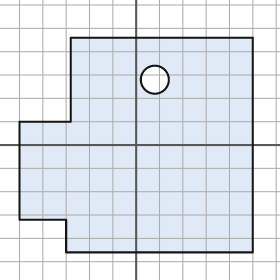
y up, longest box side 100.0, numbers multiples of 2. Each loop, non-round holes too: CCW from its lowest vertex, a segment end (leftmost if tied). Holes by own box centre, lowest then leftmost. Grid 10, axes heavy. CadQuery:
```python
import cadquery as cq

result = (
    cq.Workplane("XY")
    .moveTo(-30.0, -46.0)
    .lineTo(50.0, -46.0)
    .lineTo(50.0, 46.0)
    .lineTo(-28.0, 46.0)
    .lineTo(-28.0, 10.0)
    .lineTo(-50.0, 10.0)
    .lineTo(-50.0, -32.0)
    .lineTo(-30.0, -32.0)
    .close()
    .moveTo(8.0, 28.0)
    .circle(6.0)
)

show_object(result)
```